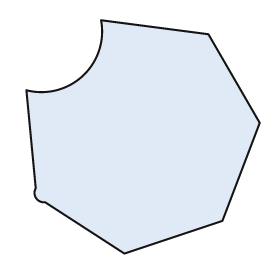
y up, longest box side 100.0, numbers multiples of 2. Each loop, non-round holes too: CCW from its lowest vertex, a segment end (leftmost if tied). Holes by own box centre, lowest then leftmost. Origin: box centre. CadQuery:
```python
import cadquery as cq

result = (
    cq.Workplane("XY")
    .moveTo(-8.0, -50.0)
    .lineTo(34.0, -36.0)
    .lineTo(50.0, 6.0)
    .lineTo(28.0, 44.0)
    .lineTo(-18.0, 50.0)
    .threePointArc((-26.0, 26.0), (-50.0, 20.0))
    .lineTo(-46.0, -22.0)
    .threePointArc((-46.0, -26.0), (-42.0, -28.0))
    .close()
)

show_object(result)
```